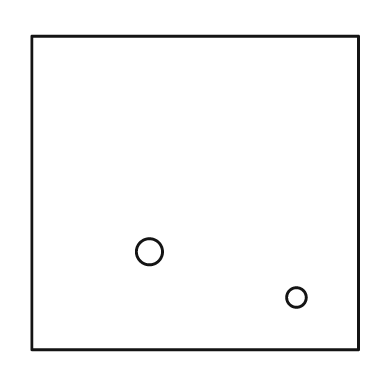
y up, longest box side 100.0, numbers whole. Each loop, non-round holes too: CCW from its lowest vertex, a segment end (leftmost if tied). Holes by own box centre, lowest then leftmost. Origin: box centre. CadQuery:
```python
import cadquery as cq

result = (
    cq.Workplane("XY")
    .moveTo(-50.0, -48.0)
    .lineTo(50.0, -48.0)
    .lineTo(50.0, 48.0)
    .lineTo(-50.0, 48.0)
    .close()
    .moveTo(31.0, -32.0)
    .circle(3.0)
    .moveTo(-14.0, -18.0)
    .circle(4.0)
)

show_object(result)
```